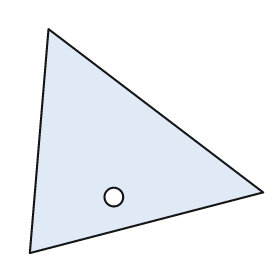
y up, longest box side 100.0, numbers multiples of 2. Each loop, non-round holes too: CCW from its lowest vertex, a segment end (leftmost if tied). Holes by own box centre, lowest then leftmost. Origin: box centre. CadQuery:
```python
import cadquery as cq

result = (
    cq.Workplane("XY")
    .moveTo(-50.0, -48.0)
    .lineTo(50.0, -22.0)
    .lineTo(-42.0, 48.0)
    .close()
    .moveTo(-14.0, -24.0)
    .circle(4.0)
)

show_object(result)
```